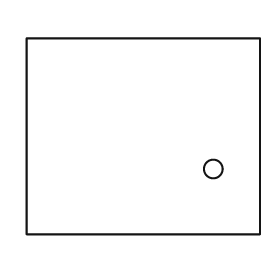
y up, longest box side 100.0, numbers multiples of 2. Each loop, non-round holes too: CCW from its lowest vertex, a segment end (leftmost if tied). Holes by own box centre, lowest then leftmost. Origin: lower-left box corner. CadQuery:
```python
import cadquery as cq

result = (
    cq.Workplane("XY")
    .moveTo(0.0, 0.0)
    .lineTo(100.0, 0.0)
    .lineTo(100.0, 84.0)
    .lineTo(0.0, 84.0)
    .close()
    .moveTo(80.0, 28.0)
    .circle(4.0)
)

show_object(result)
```